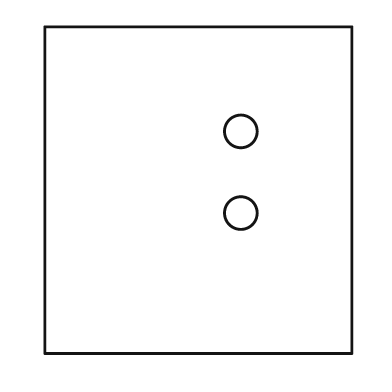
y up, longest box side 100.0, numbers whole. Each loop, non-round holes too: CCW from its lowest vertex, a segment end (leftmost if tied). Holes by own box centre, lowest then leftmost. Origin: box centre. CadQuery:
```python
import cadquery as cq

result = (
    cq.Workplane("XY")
    .moveTo(-47.0, -50.0)
    .lineTo(47.0, -50.0)
    .lineTo(47.0, 50.0)
    .lineTo(-47.0, 50.0)
    .close()
    .moveTo(13.0, -7.0)
    .circle(5.0)
    .moveTo(13.0, 18.0)
    .circle(5.0)
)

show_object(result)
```